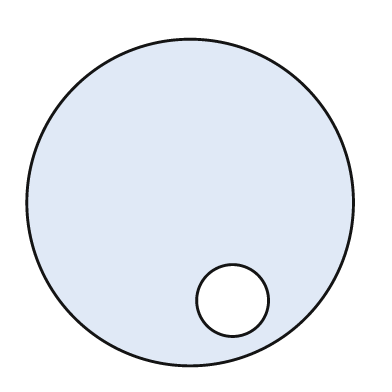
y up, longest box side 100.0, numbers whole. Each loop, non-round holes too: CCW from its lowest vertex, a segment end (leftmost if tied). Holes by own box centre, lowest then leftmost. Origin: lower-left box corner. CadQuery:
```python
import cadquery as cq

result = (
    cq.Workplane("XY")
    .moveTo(50.0, 50.0)
    .circle(50.0)
    .moveTo(63.0, 20.0)
    .circle(11.0)
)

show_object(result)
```